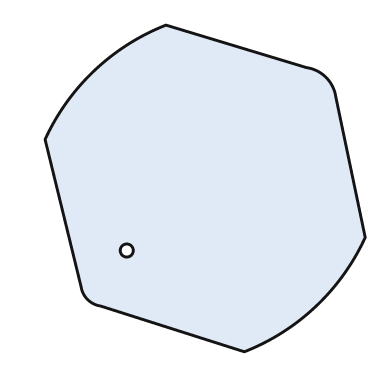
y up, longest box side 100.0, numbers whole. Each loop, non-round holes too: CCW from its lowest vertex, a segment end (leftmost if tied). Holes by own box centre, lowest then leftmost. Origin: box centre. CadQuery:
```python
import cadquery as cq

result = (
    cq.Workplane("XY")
    .moveTo(12.0, -50.0)
    .threePointArc((34.0, -36.0), (49.0, -15.0))
    .lineTo(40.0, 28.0)
    .threePointArc((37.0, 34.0), (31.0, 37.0))
    .lineTo(-12.0, 50.0)
    .threePointArc((-34.0, 36.0), (-49.0, 15.0))
    .lineTo(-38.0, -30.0)
    .threePointArc((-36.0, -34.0), (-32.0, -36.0))
    .close()
    .moveTo(-24.0, -19.0)
    .circle(2.0)
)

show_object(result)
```